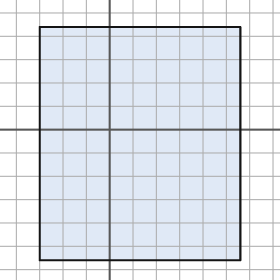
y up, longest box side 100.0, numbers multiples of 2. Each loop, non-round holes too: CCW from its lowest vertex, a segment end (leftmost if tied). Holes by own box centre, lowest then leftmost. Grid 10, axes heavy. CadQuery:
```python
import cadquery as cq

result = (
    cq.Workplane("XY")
    .moveTo(-30.0, -56.0)
    .lineTo(56.0, -56.0)
    .lineTo(56.0, 44.0)
    .lineTo(-30.0, 44.0)
    .close()
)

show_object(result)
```